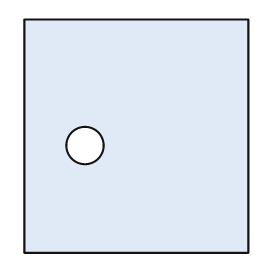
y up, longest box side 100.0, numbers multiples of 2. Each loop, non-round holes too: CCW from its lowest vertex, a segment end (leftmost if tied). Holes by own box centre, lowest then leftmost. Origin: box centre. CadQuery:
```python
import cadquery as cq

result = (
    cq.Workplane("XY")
    .moveTo(-48.0, -50.0)
    .lineTo(48.0, -50.0)
    .lineTo(48.0, 50.0)
    .lineTo(-48.0, 50.0)
    .close()
    .moveTo(-22.0, -4.0)
    .circle(8.0)
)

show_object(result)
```